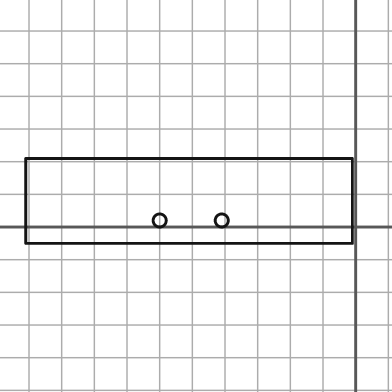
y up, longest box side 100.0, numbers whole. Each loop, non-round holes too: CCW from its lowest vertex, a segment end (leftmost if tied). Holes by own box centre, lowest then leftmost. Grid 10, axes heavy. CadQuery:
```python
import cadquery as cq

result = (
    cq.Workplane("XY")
    .moveTo(-101.0, -5.0)
    .lineTo(-1.0, -5.0)
    .lineTo(-1.0, 21.0)
    .lineTo(-101.0, 21.0)
    .close()
    .moveTo(-60.0, 2.0)
    .circle(2.0)
    .moveTo(-41.0, 2.0)
    .circle(2.0)
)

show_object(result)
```